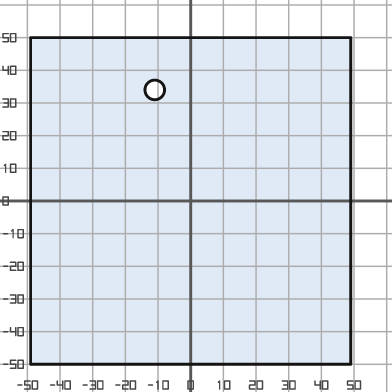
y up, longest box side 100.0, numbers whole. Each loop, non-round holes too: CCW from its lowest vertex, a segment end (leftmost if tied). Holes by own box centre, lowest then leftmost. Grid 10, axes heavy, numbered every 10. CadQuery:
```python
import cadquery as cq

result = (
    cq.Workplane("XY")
    .moveTo(-49.0, -50.0)
    .lineTo(49.0, -50.0)
    .lineTo(49.0, 50.0)
    .lineTo(-49.0, 50.0)
    .close()
    .moveTo(-11.0, 34.0)
    .circle(3.0)
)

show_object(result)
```